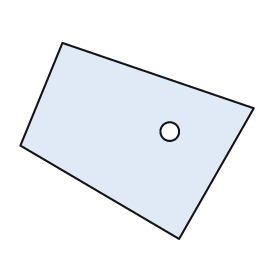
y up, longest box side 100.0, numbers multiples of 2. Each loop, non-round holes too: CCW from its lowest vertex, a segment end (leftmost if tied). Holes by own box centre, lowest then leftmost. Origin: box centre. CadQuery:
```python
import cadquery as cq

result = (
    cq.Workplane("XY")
    .moveTo(18.0, -42.0)
    .lineTo(50.0, 14.0)
    .lineTo(-32.0, 42.0)
    .lineTo(-50.0, -2.0)
    .close()
    .moveTo(14.0, 4.0)
    .circle(4.0)
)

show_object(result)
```